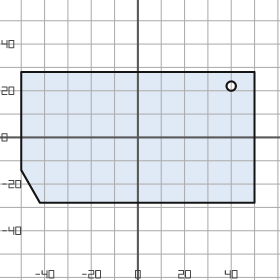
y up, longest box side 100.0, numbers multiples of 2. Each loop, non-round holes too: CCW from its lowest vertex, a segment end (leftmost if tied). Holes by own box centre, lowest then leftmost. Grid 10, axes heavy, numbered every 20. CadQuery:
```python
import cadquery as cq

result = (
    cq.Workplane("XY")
    .moveTo(-42.0, -28.0)
    .lineTo(50.0, -28.0)
    .lineTo(50.0, 28.0)
    .lineTo(-50.0, 28.0)
    .lineTo(-50.0, -14.0)
    .close()
    .moveTo(40.0, 22.0)
    .circle(2.0)
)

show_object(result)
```